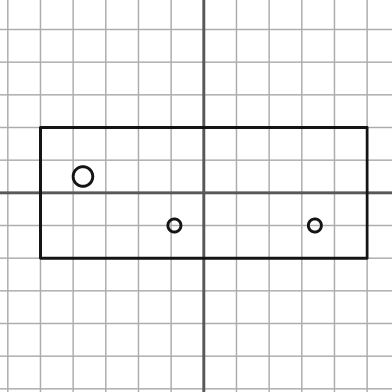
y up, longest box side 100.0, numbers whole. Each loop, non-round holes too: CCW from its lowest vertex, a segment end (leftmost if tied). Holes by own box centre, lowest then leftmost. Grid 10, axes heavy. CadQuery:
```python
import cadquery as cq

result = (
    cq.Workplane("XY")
    .moveTo(-50.0, -20.0)
    .lineTo(50.0, -20.0)
    .lineTo(50.0, 20.0)
    .lineTo(-50.0, 20.0)
    .close()
    .moveTo(-9.0, -10.0)
    .circle(2.0)
    .moveTo(34.0, -10.0)
    .circle(2.0)
    .moveTo(-37.0, 5.0)
    .circle(3.0)
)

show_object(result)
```